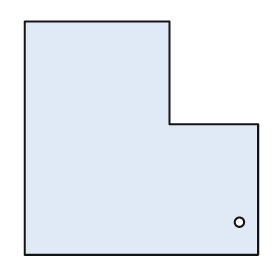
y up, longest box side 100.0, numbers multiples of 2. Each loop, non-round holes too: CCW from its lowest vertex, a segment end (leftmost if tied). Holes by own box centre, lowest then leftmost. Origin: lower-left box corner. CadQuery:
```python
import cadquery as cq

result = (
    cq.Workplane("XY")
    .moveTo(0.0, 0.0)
    .lineTo(100.0, 0.0)
    .lineTo(100.0, 56.0)
    .lineTo(62.0, 56.0)
    .lineTo(62.0, 100.0)
    .lineTo(0.0, 100.0)
    .close()
    .moveTo(92.0, 14.0)
    .circle(2.0)
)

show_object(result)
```